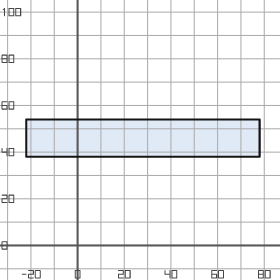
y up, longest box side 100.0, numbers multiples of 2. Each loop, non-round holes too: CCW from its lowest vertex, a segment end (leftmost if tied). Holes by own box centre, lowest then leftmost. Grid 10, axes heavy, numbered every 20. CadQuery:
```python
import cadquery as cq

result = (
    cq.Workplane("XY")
    .moveTo(-22.0, 38.0)
    .lineTo(78.0, 38.0)
    .lineTo(78.0, 54.0)
    .lineTo(-22.0, 54.0)
    .close()
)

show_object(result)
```